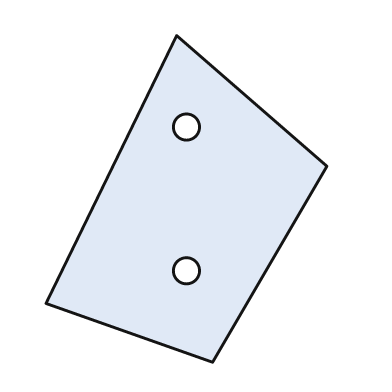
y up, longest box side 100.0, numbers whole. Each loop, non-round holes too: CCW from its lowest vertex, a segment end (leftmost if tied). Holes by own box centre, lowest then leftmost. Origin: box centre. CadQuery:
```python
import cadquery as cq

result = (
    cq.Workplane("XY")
    .moveTo(8.0, -50.0)
    .lineTo(43.0, 10.0)
    .lineTo(-3.0, 50.0)
    .lineTo(-43.0, -32.0)
    .close()
    .moveTo(0.0, -22.0)
    .circle(4.0)
    .moveTo(0.0, 22.0)
    .circle(4.0)
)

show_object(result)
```